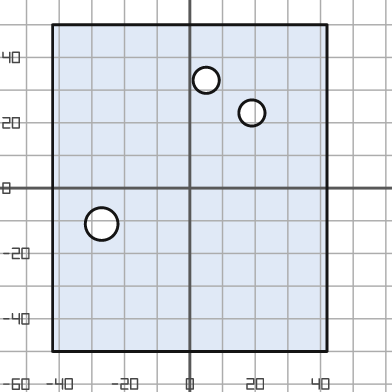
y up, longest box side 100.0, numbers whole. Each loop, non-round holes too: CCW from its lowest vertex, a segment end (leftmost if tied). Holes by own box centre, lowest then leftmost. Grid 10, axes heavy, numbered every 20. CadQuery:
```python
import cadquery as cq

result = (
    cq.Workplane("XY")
    .moveTo(-42.0, -50.0)
    .lineTo(42.0, -50.0)
    .lineTo(42.0, 50.0)
    .lineTo(-42.0, 50.0)
    .close()
    .moveTo(-27.0, -11.0)
    .circle(5.0)
    .moveTo(19.0, 23.0)
    .circle(4.0)
    .moveTo(5.0, 33.0)
    .circle(4.0)
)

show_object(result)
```